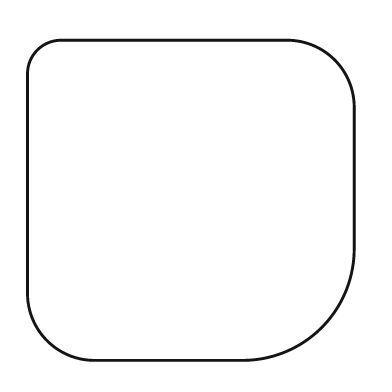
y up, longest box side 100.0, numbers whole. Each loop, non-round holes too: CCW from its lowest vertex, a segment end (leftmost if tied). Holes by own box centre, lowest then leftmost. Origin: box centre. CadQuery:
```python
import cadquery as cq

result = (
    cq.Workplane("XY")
    .moveTo(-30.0, -49.0)
    .lineTo(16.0, -49.0)
    .threePointArc((40.0, -39.0), (50.0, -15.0))
    .lineTo(50.0, 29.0)
    .threePointArc((44.0, 43.0), (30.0, 49.0))
    .lineTo(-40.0, 49.0)
    .threePointArc((-47.0, 46.0), (-50.0, 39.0))
    .lineTo(-50.0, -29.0)
    .threePointArc((-44.0, -43.0), (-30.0, -49.0))
    .close()
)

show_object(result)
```